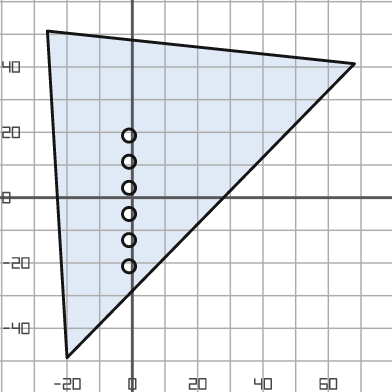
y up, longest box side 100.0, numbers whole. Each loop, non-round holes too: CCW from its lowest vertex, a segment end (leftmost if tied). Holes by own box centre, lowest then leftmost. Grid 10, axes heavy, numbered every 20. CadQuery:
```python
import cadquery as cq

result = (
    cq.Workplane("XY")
    .moveTo(-20.0, -49.0)
    .lineTo(68.0, 41.0)
    .lineTo(-26.0, 51.0)
    .close()
    .moveTo(-1.0, -21.0)
    .circle(2.0)
    .moveTo(-1.0, -13.0)
    .circle(2.0)
    .moveTo(-1.0, -5.0)
    .circle(2.0)
    .moveTo(-1.0, 3.0)
    .circle(2.0)
    .moveTo(-1.0, 11.0)
    .circle(2.0)
    .moveTo(-1.0, 19.0)
    .circle(2.0)
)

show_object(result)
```